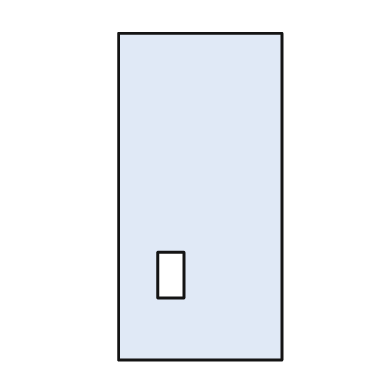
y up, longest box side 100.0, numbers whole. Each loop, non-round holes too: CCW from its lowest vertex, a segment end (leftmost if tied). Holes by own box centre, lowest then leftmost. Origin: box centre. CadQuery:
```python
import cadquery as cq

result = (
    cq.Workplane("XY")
    .moveTo(-25.0, -50.0)
    .lineTo(25.0, -50.0)
    .lineTo(25.0, 50.0)
    .lineTo(-25.0, 50.0)
    .close()
    .moveTo(-13.0, -31.0)
    .lineTo(-5.0, -31.0)
    .lineTo(-5.0, -17.0)
    .lineTo(-13.0, -17.0)
    .close()
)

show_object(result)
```